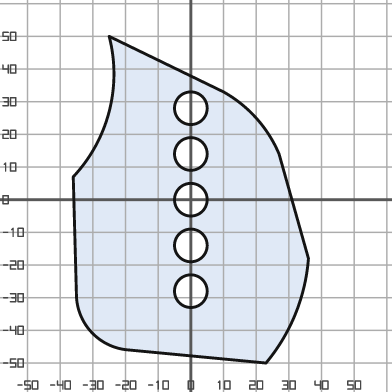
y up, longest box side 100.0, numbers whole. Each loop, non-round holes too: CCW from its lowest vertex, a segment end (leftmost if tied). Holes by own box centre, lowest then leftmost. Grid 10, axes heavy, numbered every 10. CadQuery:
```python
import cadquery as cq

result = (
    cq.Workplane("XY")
    .moveTo(23.0, -50.0)
    .threePointArc((32.0, -35.0), (36.0, -18.0))
    .lineTo(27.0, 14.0)
    .threePointArc((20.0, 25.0), (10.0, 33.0))
    .lineTo(-25.0, 50.0)
    .threePointArc((-25.0, 27.0), (-36.0, 7.0))
    .lineTo(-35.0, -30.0)
    .threePointArc((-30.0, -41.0), (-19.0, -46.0))
    .close()
    .moveTo(0.0, -28.0)
    .circle(5.0)
    .moveTo(0.0, -14.0)
    .circle(5.0)
    .moveTo(0.0, 0.0)
    .circle(5.0)
    .moveTo(0.0, 14.0)
    .circle(5.0)
    .moveTo(0.0, 28.0)
    .circle(5.0)
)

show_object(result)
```